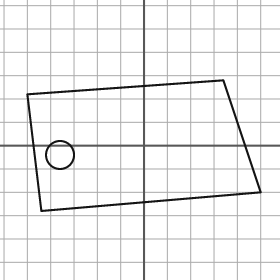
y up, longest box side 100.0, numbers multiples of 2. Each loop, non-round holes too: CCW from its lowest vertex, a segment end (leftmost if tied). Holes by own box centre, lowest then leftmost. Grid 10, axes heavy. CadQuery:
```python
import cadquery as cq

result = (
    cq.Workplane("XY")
    .moveTo(-44.0, -28.0)
    .lineTo(50.0, -20.0)
    .lineTo(34.0, 28.0)
    .lineTo(-50.0, 22.0)
    .close()
    .moveTo(-36.0, -4.0)
    .circle(6.0)
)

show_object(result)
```